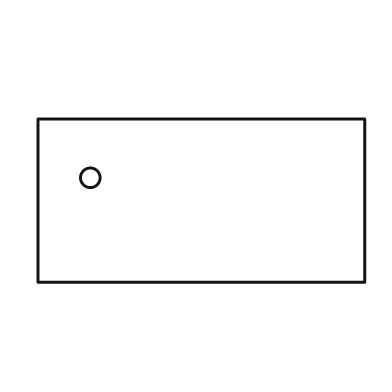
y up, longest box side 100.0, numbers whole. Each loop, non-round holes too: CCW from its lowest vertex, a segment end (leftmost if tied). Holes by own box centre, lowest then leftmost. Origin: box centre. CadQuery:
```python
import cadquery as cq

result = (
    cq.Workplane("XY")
    .moveTo(-50.0, -25.0)
    .lineTo(50.0, -25.0)
    .lineTo(50.0, 25.0)
    .lineTo(-50.0, 25.0)
    .close()
    .moveTo(-34.0, 7.0)
    .circle(3.0)
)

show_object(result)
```